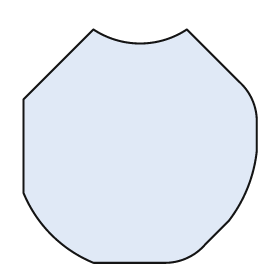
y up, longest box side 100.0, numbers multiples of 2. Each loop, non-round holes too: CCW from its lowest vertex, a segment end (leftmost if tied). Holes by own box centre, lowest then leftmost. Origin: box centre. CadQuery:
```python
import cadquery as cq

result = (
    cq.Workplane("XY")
    .moveTo(-20.0, -50.0)
    .lineTo(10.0, -50.0)
    .threePointArc((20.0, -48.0), (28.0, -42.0))
    .lineTo(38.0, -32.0)
    .threePointArc((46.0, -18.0), (50.0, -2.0))
    .lineTo(50.0, 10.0)
    .threePointArc((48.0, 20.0), (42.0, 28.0))
    .lineTo(20.0, 50.0)
    .threePointArc((0.0, 44.0), (-20.0, 50.0))
    .lineTo(-50.0, 20.0)
    .lineTo(-50.0, -20.0)
    .threePointArc((-38.0, -38.0), (-20.0, -50.0))
    .close()
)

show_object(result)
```